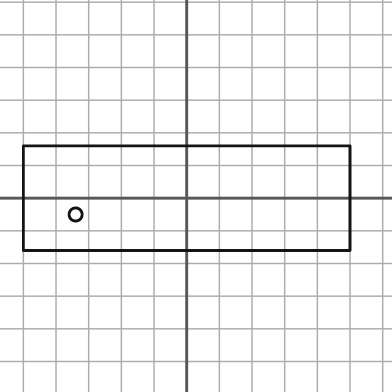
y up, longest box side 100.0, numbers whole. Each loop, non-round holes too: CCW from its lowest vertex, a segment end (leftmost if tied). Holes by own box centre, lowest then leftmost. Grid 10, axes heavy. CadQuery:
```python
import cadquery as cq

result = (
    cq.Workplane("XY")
    .moveTo(-50.0, -16.0)
    .lineTo(50.0, -16.0)
    .lineTo(50.0, 16.0)
    .lineTo(-50.0, 16.0)
    .close()
    .moveTo(-34.0, -5.0)
    .circle(2.0)
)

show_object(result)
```